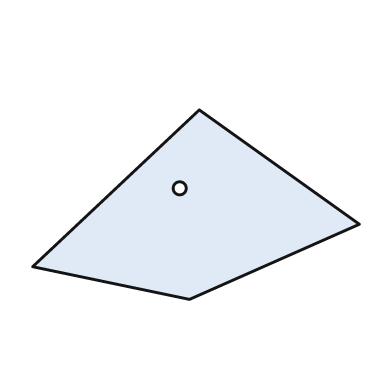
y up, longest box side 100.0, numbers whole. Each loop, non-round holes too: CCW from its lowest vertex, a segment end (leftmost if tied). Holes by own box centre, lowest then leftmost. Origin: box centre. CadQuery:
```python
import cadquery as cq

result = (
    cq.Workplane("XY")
    .moveTo(-2.0, -29.0)
    .lineTo(50.0, -6.0)
    .lineTo(1.0, 29.0)
    .lineTo(-50.0, -19.0)
    .close()
    .moveTo(-5.0, 5.0)
    .circle(2.0)
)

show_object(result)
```